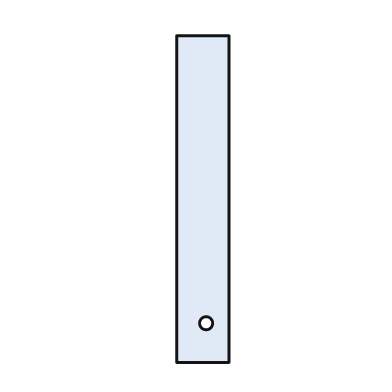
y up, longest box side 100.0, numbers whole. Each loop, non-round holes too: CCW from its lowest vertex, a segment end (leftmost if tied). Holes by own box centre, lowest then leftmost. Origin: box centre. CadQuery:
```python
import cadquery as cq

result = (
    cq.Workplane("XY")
    .moveTo(-8.0, -50.0)
    .lineTo(8.0, -50.0)
    .lineTo(8.0, 50.0)
    .lineTo(-8.0, 50.0)
    .close()
    .moveTo(1.0, -38.0)
    .circle(2.0)
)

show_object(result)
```